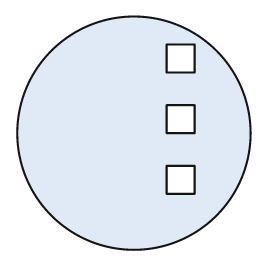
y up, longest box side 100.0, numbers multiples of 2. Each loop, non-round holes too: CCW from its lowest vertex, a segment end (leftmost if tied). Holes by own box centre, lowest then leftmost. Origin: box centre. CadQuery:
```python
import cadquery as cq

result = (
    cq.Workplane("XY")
    .moveTo(0.0, 0.0)
    .circle(50.0)
    .moveTo(14.0, -26.0)
    .lineTo(26.0, -26.0)
    .lineTo(26.0, -14.0)
    .lineTo(14.0, -14.0)
    .close()
    .moveTo(14.0, 0.0)
    .lineTo(26.0, 0.0)
    .lineTo(26.0, 12.0)
    .lineTo(14.0, 12.0)
    .close()
    .moveTo(14.0, 26.0)
    .lineTo(26.0, 26.0)
    .lineTo(26.0, 38.0)
    .lineTo(14.0, 38.0)
    .close()
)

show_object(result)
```